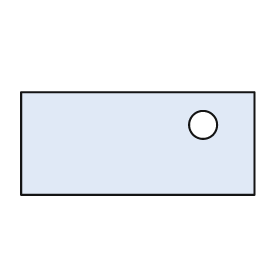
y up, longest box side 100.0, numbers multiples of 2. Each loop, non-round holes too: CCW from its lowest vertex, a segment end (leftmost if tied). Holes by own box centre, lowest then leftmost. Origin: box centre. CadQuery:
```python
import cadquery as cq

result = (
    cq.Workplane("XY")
    .moveTo(-50.0, -22.0)
    .lineTo(50.0, -22.0)
    .lineTo(50.0, 22.0)
    .lineTo(-50.0, 22.0)
    .close()
    .moveTo(28.0, 8.0)
    .circle(6.0)
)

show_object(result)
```